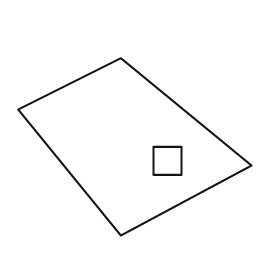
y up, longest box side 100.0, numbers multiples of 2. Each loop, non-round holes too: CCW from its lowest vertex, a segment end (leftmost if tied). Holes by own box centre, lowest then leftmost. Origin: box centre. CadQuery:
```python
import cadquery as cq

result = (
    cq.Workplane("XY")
    .moveTo(-6.0, -38.0)
    .lineTo(50.0, -8.0)
    .lineTo(-6.0, 38.0)
    .lineTo(-50.0, 16.0)
    .close()
    .moveTo(8.0, -12.0)
    .lineTo(20.0, -12.0)
    .lineTo(20.0, 0.0)
    .lineTo(8.0, 0.0)
    .close()
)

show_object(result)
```